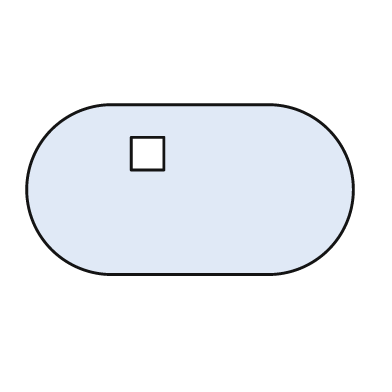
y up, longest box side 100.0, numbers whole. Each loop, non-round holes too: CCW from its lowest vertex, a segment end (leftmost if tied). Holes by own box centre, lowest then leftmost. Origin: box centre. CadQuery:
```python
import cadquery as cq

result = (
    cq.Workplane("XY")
    .moveTo(-24.0, -26.0)
    .lineTo(24.0, -26.0)
    .threePointArc((50.0, 0.0), (24.0, 26.0))
    .lineTo(-24.0, 26.0)
    .threePointArc((-50.0, 0.0), (-24.0, -26.0))
    .close()
    .moveTo(-18.0, 6.0)
    .lineTo(-8.0, 6.0)
    .lineTo(-8.0, 16.0)
    .lineTo(-18.0, 16.0)
    .close()
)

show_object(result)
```